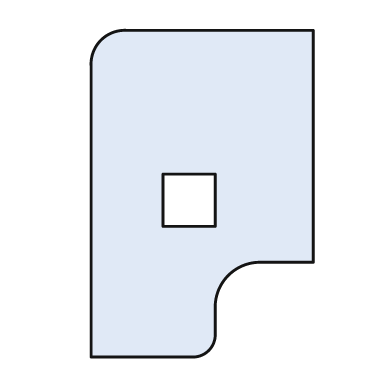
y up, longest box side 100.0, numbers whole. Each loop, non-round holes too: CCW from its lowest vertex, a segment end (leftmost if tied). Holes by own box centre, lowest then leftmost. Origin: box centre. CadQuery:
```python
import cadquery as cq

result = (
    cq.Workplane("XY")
    .moveTo(-34.0, -50.0)
    .lineTo(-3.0, -50.0)
    .threePointArc((2.0, -48.0), (4.0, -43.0))
    .lineTo(4.0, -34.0)
    .threePointArc((8.0, -25.0), (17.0, -21.0))
    .lineTo(34.0, -21.0)
    .lineTo(34.0, 50.0)
    .lineTo(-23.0, 50.0)
    .threePointArc((-31.0, 47.0), (-34.0, 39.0))
    .close()
    .moveTo(-12.0, -10.0)
    .lineTo(4.0, -10.0)
    .lineTo(4.0, 6.0)
    .lineTo(-12.0, 6.0)
    .close()
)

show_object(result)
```